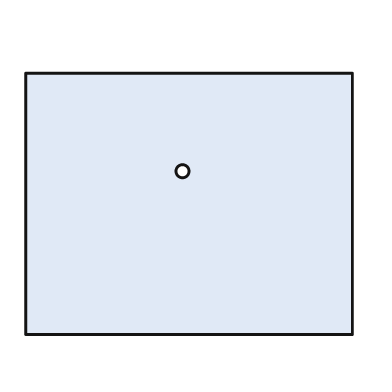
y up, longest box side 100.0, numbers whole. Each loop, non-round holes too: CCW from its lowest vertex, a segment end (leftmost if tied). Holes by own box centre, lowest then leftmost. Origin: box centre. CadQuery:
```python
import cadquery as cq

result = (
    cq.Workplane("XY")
    .moveTo(-50.0, -40.0)
    .lineTo(50.0, -40.0)
    .lineTo(50.0, 40.0)
    .lineTo(-50.0, 40.0)
    .close()
    .moveTo(-2.0, 10.0)
    .circle(2.0)
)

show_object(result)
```